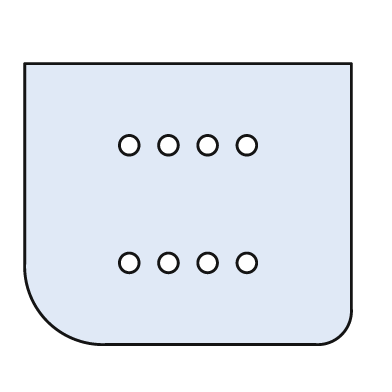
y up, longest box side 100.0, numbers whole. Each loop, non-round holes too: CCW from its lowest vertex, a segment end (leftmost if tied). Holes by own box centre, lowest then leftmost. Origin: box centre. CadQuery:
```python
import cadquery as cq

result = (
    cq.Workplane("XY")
    .moveTo(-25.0, -43.0)
    .lineTo(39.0, -43.0)
    .threePointArc((47.0, -40.0), (50.0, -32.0))
    .lineTo(50.0, 43.0)
    .lineTo(-50.0, 43.0)
    .lineTo(-50.0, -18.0)
    .threePointArc((-43.0, -36.0), (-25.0, -43.0))
    .close()
    .moveTo(-18.0, -18.0)
    .circle(3.0)
    .moveTo(-6.0, -18.0)
    .circle(3.0)
    .moveTo(6.0, -18.0)
    .circle(3.0)
    .moveTo(18.0, -18.0)
    .circle(3.0)
    .moveTo(-18.0, 18.0)
    .circle(3.0)
    .moveTo(-6.0, 18.0)
    .circle(3.0)
    .moveTo(6.0, 18.0)
    .circle(3.0)
    .moveTo(18.0, 18.0)
    .circle(3.0)
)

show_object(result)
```